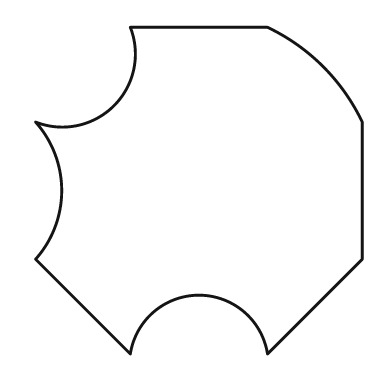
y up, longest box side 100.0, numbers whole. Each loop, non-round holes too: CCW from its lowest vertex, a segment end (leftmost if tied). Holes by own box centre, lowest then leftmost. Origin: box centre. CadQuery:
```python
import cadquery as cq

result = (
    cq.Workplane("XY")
    .moveTo(-21.0, -50.0)
    .threePointArc((0.0, -32.0), (21.0, -50.0))
    .lineTo(50.0, -21.0)
    .lineTo(50.0, 21.0)
    .threePointArc((38.0, 38.0), (21.0, 50.0))
    .lineTo(-21.0, 50.0)
    .threePointArc((-26.0, 26.0), (-50.0, 21.0))
    .threePointArc((-42.0, 0.0), (-50.0, -21.0))
    .close()
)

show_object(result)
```